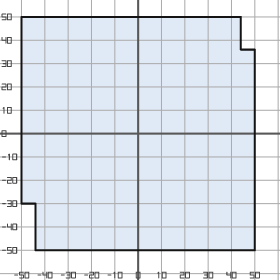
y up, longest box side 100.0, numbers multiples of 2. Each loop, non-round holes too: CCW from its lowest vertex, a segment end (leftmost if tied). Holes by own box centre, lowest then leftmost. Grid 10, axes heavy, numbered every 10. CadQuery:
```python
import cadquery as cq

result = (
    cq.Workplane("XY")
    .moveTo(-44.0, -50.0)
    .lineTo(50.0, -50.0)
    .lineTo(50.0, 36.0)
    .lineTo(44.0, 36.0)
    .lineTo(44.0, 50.0)
    .lineTo(-50.0, 50.0)
    .lineTo(-50.0, -30.0)
    .lineTo(-44.0, -30.0)
    .close()
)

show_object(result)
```